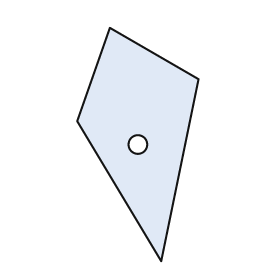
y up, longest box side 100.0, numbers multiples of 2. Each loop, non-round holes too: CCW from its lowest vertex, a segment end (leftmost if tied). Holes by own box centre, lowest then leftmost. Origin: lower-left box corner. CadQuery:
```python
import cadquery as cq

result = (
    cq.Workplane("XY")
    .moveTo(36.0, 0.0)
    .lineTo(52.0, 78.0)
    .lineTo(14.0, 100.0)
    .lineTo(0.0, 60.0)
    .close()
    .moveTo(26.0, 50.0)
    .circle(4.0)
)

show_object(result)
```